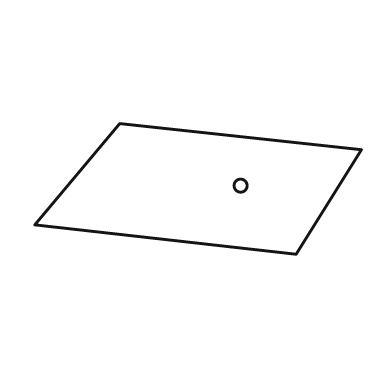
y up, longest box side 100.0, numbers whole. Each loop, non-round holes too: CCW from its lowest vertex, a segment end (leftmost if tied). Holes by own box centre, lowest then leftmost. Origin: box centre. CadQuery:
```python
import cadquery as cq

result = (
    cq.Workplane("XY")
    .moveTo(30.0, -20.0)
    .lineTo(50.0, 12.0)
    .lineTo(-24.0, 20.0)
    .lineTo(-50.0, -11.0)
    .close()
    .moveTo(13.0, 1.0)
    .circle(2.0)
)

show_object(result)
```